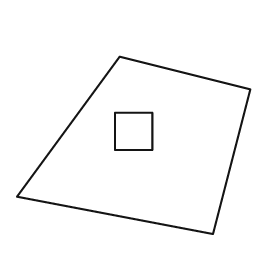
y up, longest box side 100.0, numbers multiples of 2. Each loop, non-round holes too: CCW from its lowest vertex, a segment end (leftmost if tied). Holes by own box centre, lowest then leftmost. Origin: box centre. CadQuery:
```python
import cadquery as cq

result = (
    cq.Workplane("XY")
    .moveTo(34.0, -38.0)
    .lineTo(50.0, 24.0)
    .lineTo(-6.0, 38.0)
    .lineTo(-50.0, -22.0)
    .close()
    .moveTo(-8.0, -2.0)
    .lineTo(8.0, -2.0)
    .lineTo(8.0, 14.0)
    .lineTo(-8.0, 14.0)
    .close()
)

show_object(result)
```